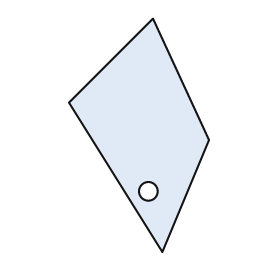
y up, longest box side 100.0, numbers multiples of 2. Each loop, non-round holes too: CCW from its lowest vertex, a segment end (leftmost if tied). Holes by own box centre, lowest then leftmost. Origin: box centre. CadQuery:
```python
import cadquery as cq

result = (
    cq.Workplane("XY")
    .moveTo(10.0, -50.0)
    .lineTo(30.0, -2.0)
    .lineTo(6.0, 50.0)
    .lineTo(-30.0, 14.0)
    .close()
    .moveTo(4.0, -24.0)
    .circle(4.0)
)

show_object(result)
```